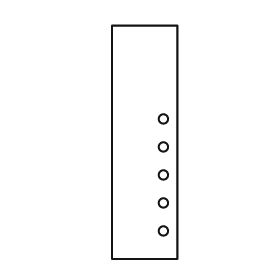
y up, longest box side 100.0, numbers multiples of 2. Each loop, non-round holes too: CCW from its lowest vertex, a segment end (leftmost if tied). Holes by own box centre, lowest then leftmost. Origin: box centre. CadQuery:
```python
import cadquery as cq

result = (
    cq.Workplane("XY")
    .moveTo(-14.0, -50.0)
    .lineTo(14.0, -50.0)
    .lineTo(14.0, 50.0)
    .lineTo(-14.0, 50.0)
    .close()
    .moveTo(8.0, -38.0)
    .circle(2.0)
    .moveTo(8.0, -26.0)
    .circle(2.0)
    .moveTo(8.0, -14.0)
    .circle(2.0)
    .moveTo(8.0, -2.0)
    .circle(2.0)
    .moveTo(8.0, 10.0)
    .circle(2.0)
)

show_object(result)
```